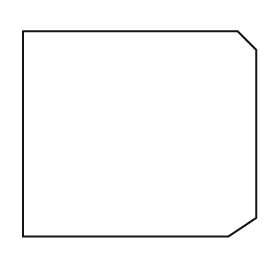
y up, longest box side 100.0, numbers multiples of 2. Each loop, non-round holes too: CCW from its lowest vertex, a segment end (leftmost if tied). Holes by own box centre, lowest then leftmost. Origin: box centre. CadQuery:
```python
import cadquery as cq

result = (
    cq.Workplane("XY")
    .moveTo(-50.0, -44.0)
    .lineTo(38.0, -44.0)
    .lineTo(50.0, -36.0)
    .lineTo(50.0, 36.0)
    .lineTo(42.0, 44.0)
    .lineTo(-50.0, 44.0)
    .close()
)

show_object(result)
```